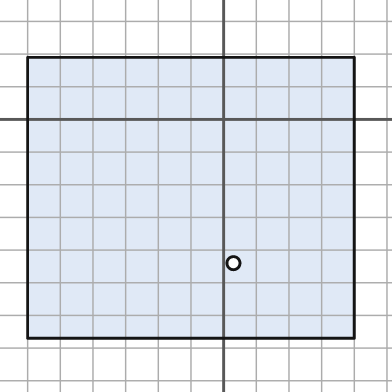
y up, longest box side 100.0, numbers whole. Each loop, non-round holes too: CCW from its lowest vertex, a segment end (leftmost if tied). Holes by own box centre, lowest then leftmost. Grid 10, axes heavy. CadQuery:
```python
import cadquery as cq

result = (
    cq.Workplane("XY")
    .moveTo(-60.0, -67.0)
    .lineTo(40.0, -67.0)
    .lineTo(40.0, 19.0)
    .lineTo(-60.0, 19.0)
    .close()
    .moveTo(3.0, -44.0)
    .circle(2.0)
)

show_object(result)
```